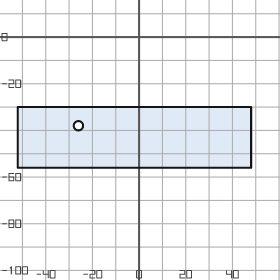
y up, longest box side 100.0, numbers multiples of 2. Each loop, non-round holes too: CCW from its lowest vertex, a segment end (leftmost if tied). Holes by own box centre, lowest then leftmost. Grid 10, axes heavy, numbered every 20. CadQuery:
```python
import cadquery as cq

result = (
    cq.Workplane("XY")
    .moveTo(-52.0, -56.0)
    .lineTo(48.0, -56.0)
    .lineTo(48.0, -30.0)
    .lineTo(-52.0, -30.0)
    .close()
    .moveTo(-26.0, -38.0)
    .circle(2.0)
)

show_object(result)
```